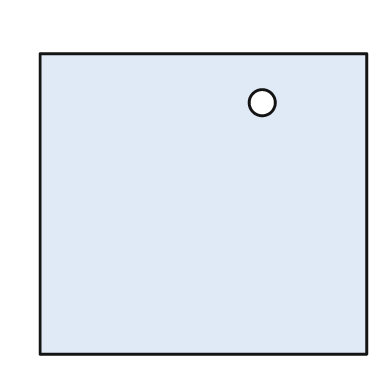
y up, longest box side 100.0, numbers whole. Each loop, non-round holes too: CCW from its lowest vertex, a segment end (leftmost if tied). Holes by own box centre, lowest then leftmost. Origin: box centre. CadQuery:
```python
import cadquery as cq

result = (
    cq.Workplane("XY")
    .moveTo(-50.0, -46.0)
    .lineTo(50.0, -46.0)
    .lineTo(50.0, 46.0)
    .lineTo(-50.0, 46.0)
    .close()
    .moveTo(18.0, 31.0)
    .circle(4.0)
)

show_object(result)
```